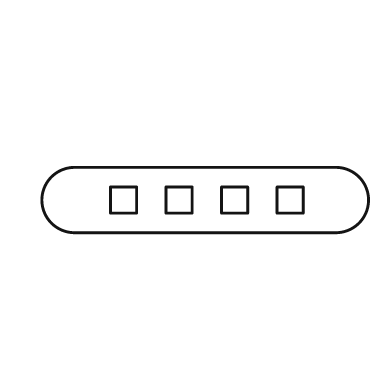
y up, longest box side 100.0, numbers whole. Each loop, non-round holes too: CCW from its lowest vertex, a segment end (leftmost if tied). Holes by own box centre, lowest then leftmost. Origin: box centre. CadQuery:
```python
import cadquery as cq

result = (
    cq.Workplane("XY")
    .moveTo(-40.0, -10.0)
    .lineTo(40.0, -10.0)
    .threePointArc((50.0, 0.0), (40.0, 10.0))
    .lineTo(-40.0, 10.0)
    .threePointArc((-50.0, 0.0), (-40.0, -10.0))
    .close()
    .moveTo(-29.0, -4.0)
    .lineTo(-21.0, -4.0)
    .lineTo(-21.0, 4.0)
    .lineTo(-29.0, 4.0)
    .close()
    .moveTo(-12.0, -4.0)
    .lineTo(-4.0, -4.0)
    .lineTo(-4.0, 4.0)
    .lineTo(-12.0, 4.0)
    .close()
    .moveTo(5.0, -4.0)
    .lineTo(13.0, -4.0)
    .lineTo(13.0, 4.0)
    .lineTo(5.0, 4.0)
    .close()
    .moveTo(22.0, -4.0)
    .lineTo(30.0, -4.0)
    .lineTo(30.0, 4.0)
    .lineTo(22.0, 4.0)
    .close()
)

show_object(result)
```